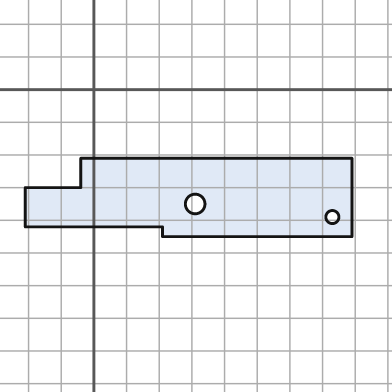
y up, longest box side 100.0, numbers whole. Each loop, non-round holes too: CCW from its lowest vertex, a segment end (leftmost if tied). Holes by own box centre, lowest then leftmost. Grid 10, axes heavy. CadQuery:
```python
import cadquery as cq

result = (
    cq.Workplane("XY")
    .moveTo(21.0, -45.0)
    .lineTo(79.0, -45.0)
    .lineTo(79.0, -21.0)
    .lineTo(-4.0, -21.0)
    .lineTo(-4.0, -30.0)
    .lineTo(-21.0, -30.0)
    .lineTo(-21.0, -42.0)
    .lineTo(21.0, -42.0)
    .close()
    .moveTo(73.0, -39.0)
    .circle(2.0)
    .moveTo(31.0, -35.0)
    .circle(3.0)
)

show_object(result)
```